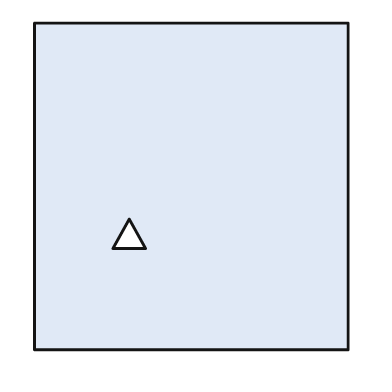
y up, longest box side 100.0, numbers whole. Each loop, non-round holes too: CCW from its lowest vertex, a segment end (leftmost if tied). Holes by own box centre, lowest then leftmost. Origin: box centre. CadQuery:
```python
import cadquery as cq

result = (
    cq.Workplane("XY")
    .moveTo(-48.0, -50.0)
    .lineTo(48.0, -50.0)
    .lineTo(48.0, 50.0)
    .lineTo(-48.0, 50.0)
    .close()
    .moveTo(-24.0, -19.0)
    .lineTo(-14.0, -19.0)
    .lineTo(-19.0, -10.0)
    .close()
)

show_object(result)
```